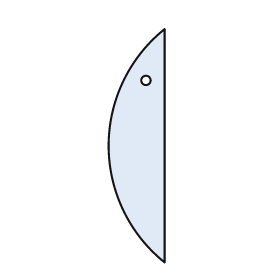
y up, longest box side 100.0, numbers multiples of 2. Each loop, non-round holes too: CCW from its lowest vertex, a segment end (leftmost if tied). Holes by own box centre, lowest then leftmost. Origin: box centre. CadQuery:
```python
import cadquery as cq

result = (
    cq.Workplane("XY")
    .moveTo(12.0, -50.0)
    .lineTo(12.0, 50.0)
    .threePointArc((-12.0, 0.0), (12.0, -50.0))
    .close()
    .moveTo(4.0, 28.0)
    .circle(2.0)
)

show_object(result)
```